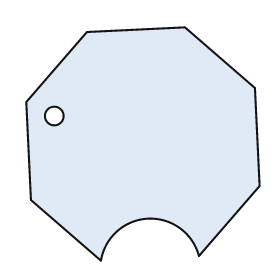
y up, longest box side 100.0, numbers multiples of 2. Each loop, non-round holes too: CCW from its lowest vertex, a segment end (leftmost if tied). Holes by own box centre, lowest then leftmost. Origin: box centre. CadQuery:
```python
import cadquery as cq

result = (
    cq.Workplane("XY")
    .moveTo(-18.0, -50.0)
    .threePointArc((2.0, -32.0), (24.0, -48.0))
    .lineTo(50.0, -18.0)
    .lineTo(48.0, 24.0)
    .lineTo(18.0, 50.0)
    .lineTo(-24.0, 48.0)
    .lineTo(-50.0, 18.0)
    .lineTo(-48.0, -24.0)
    .close()
    .moveTo(-38.0, 12.0)
    .circle(4.0)
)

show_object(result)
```